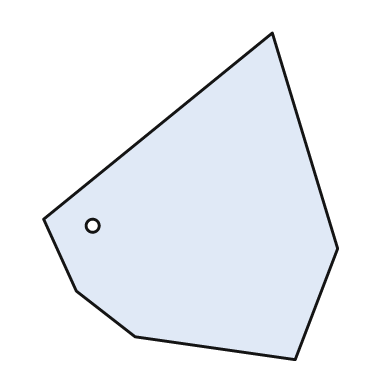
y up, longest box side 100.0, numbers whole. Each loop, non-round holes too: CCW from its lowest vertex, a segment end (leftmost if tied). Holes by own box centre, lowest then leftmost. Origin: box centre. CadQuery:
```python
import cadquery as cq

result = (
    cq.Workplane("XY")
    .moveTo(32.0, -50.0)
    .lineTo(45.0, -16.0)
    .lineTo(25.0, 50.0)
    .lineTo(-45.0, -7.0)
    .lineTo(-35.0, -29.0)
    .lineTo(-17.0, -43.0)
    .close()
    .moveTo(-30.0, -9.0)
    .circle(2.0)
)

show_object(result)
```